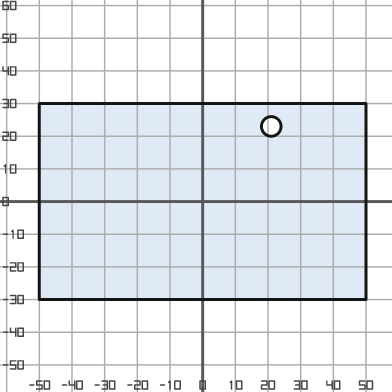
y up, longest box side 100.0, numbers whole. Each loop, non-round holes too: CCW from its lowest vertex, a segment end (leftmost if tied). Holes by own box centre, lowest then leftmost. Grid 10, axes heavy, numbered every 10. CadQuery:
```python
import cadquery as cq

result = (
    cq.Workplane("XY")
    .moveTo(-50.0, -30.0)
    .lineTo(50.0, -30.0)
    .lineTo(50.0, 30.0)
    .lineTo(-50.0, 30.0)
    .close()
    .moveTo(21.0, 23.0)
    .circle(3.0)
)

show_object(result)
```